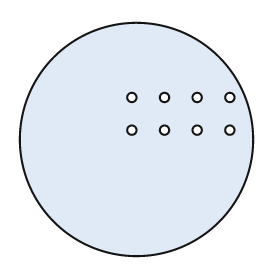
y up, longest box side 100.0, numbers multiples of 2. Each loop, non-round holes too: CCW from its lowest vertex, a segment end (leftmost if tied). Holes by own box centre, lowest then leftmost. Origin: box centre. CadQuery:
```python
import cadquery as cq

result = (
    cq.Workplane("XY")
    .moveTo(0.0, 0.0)
    .circle(50.0)
    .moveTo(-2.0, 4.0)
    .circle(2.0)
    .moveTo(12.0, 4.0)
    .circle(2.0)
    .moveTo(26.0, 4.0)
    .circle(2.0)
    .moveTo(40.0, 4.0)
    .circle(2.0)
    .moveTo(-2.0, 18.0)
    .circle(2.0)
    .moveTo(12.0, 18.0)
    .circle(2.0)
    .moveTo(26.0, 18.0)
    .circle(2.0)
    .moveTo(40.0, 18.0)
    .circle(2.0)
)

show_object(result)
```